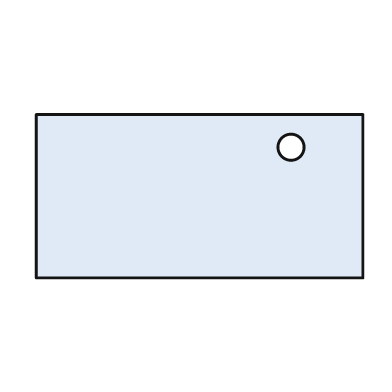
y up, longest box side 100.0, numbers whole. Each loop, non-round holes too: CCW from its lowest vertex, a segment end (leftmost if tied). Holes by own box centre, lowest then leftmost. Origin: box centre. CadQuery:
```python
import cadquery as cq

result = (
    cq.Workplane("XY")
    .moveTo(-50.0, -25.0)
    .lineTo(50.0, -25.0)
    .lineTo(50.0, 25.0)
    .lineTo(-50.0, 25.0)
    .close()
    .moveTo(28.0, 15.0)
    .circle(4.0)
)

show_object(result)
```